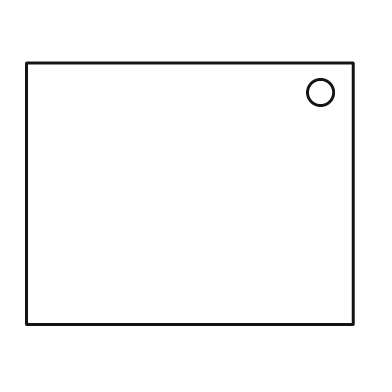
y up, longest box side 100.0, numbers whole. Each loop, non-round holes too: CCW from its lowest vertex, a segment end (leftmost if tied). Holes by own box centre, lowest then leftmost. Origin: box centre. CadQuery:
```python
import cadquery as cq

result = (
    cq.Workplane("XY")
    .moveTo(-50.0, -40.0)
    .lineTo(50.0, -40.0)
    .lineTo(50.0, 40.0)
    .lineTo(-50.0, 40.0)
    .close()
    .moveTo(40.0, 31.0)
    .circle(4.0)
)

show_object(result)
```